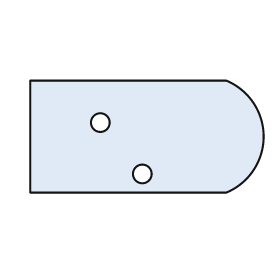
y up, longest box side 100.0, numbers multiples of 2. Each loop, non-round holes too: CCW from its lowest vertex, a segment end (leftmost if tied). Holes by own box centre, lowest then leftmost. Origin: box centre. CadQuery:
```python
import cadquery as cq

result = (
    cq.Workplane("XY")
    .moveTo(-50.0, -24.0)
    .lineTo(34.0, -24.0)
    .threePointArc((50.0, 0.0), (34.0, 24.0))
    .lineTo(-50.0, 24.0)
    .close()
    .moveTo(-2.0, -16.0)
    .circle(4.0)
    .moveTo(-20.0, 6.0)
    .circle(4.0)
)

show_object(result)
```